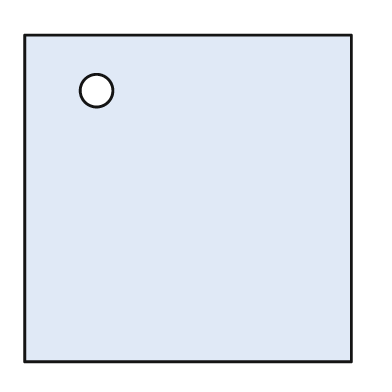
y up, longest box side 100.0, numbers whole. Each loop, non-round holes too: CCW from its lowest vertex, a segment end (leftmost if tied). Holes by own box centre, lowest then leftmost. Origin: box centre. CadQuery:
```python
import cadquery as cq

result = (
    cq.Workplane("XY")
    .moveTo(-50.0, -50.0)
    .lineTo(50.0, -50.0)
    .lineTo(50.0, 50.0)
    .lineTo(-50.0, 50.0)
    .close()
    .moveTo(-28.0, 33.0)
    .circle(5.0)
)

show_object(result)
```